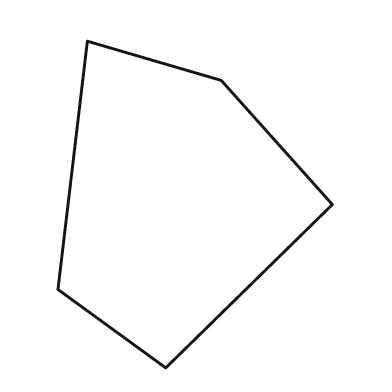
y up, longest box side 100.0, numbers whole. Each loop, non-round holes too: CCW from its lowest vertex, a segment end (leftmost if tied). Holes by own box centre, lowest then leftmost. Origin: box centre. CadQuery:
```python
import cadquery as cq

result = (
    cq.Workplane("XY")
    .moveTo(-9.0, -50.0)
    .lineTo(42.0, 0.0)
    .lineTo(8.0, 38.0)
    .lineTo(-33.0, 50.0)
    .lineTo(-42.0, -26.0)
    .close()
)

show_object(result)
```